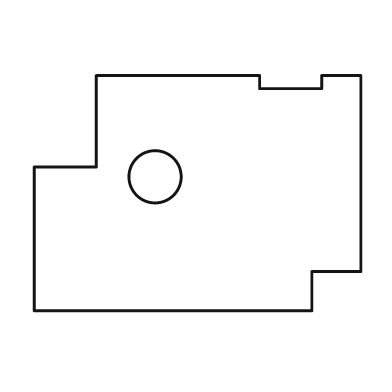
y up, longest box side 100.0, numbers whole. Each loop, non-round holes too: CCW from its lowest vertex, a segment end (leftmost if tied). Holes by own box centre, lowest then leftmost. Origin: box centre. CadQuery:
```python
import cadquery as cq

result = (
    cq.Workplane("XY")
    .moveTo(-50.0, -36.0)
    .lineTo(35.0, -36.0)
    .lineTo(35.0, -24.0)
    .lineTo(50.0, -24.0)
    .lineTo(50.0, 36.0)
    .lineTo(38.0, 36.0)
    .lineTo(38.0, 32.0)
    .lineTo(19.0, 32.0)
    .lineTo(19.0, 36.0)
    .lineTo(-31.0, 36.0)
    .lineTo(-31.0, 8.0)
    .lineTo(-50.0, 8.0)
    .close()
    .moveTo(-13.0, 5.0)
    .circle(8.0)
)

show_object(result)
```